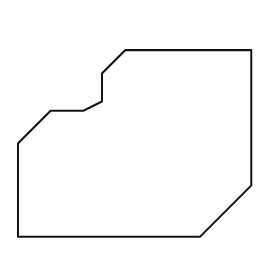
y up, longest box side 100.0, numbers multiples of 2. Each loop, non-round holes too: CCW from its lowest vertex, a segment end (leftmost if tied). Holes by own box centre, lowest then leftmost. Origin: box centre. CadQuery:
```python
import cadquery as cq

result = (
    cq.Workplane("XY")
    .moveTo(-50.0, -40.0)
    .lineTo(28.0, -40.0)
    .lineTo(50.0, -18.0)
    .lineTo(50.0, 40.0)
    .lineTo(-4.0, 40.0)
    .lineTo(-14.0, 30.0)
    .lineTo(-14.0, 18.0)
    .lineTo(-22.0, 14.0)
    .lineTo(-36.0, 14.0)
    .lineTo(-50.0, 0.0)
    .close()
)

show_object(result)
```